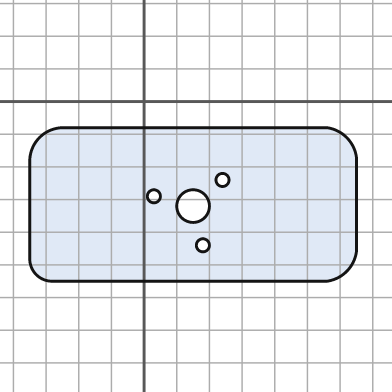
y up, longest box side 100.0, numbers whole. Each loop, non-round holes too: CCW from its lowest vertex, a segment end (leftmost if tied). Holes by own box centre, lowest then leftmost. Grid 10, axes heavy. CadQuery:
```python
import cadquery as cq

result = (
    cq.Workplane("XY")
    .moveTo(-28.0, -55.0)
    .lineTo(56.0, -55.0)
    .threePointArc((62.0, -52.0), (65.0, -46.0))
    .lineTo(65.0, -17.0)
    .threePointArc((62.0, -11.0), (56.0, -8.0))
    .lineTo(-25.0, -8.0)
    .threePointArc((-32.0, -11.0), (-35.0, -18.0))
    .lineTo(-35.0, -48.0)
    .threePointArc((-33.0, -53.0), (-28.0, -55.0))
    .close()
    .moveTo(18.0, -44.0)
    .circle(2.0)
    .moveTo(15.0, -32.0)
    .circle(5.0)
    .moveTo(3.0, -29.0)
    .circle(2.0)
    .moveTo(24.0, -24.0)
    .circle(2.0)
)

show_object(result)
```